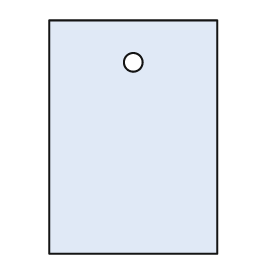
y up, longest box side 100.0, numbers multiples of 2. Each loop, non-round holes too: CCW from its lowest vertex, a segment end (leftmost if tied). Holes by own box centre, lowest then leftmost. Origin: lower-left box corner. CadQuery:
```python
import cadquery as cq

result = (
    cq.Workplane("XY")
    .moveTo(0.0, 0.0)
    .lineTo(72.0, 0.0)
    .lineTo(72.0, 100.0)
    .lineTo(0.0, 100.0)
    .close()
    .moveTo(36.0, 82.0)
    .circle(4.0)
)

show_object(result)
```